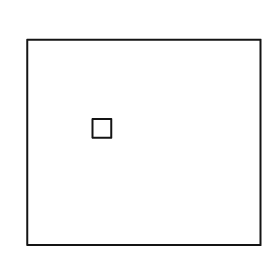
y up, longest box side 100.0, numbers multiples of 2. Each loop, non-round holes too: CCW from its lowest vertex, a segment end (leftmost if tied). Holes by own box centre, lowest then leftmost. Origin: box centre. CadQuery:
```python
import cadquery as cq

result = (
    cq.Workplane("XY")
    .moveTo(-50.0, -44.0)
    .lineTo(50.0, -44.0)
    .lineTo(50.0, 44.0)
    .lineTo(-50.0, 44.0)
    .close()
    .moveTo(-22.0, 2.0)
    .lineTo(-14.0, 2.0)
    .lineTo(-14.0, 10.0)
    .lineTo(-22.0, 10.0)
    .close()
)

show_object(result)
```